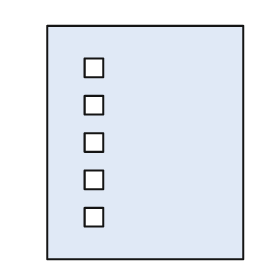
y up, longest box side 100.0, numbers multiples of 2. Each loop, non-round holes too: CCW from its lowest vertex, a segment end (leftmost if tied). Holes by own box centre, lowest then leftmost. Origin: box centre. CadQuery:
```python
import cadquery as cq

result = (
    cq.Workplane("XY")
    .moveTo(-42.0, -50.0)
    .lineTo(42.0, -50.0)
    .lineTo(42.0, 50.0)
    .lineTo(-42.0, 50.0)
    .close()
    .moveTo(-26.0, -36.0)
    .lineTo(-18.0, -36.0)
    .lineTo(-18.0, -28.0)
    .lineTo(-26.0, -28.0)
    .close()
    .moveTo(-26.0, -20.0)
    .lineTo(-18.0, -20.0)
    .lineTo(-18.0, -12.0)
    .lineTo(-26.0, -12.0)
    .close()
    .moveTo(-26.0, -4.0)
    .lineTo(-18.0, -4.0)
    .lineTo(-18.0, 4.0)
    .lineTo(-26.0, 4.0)
    .close()
    .moveTo(-26.0, 12.0)
    .lineTo(-18.0, 12.0)
    .lineTo(-18.0, 20.0)
    .lineTo(-26.0, 20.0)
    .close()
    .moveTo(-26.0, 28.0)
    .lineTo(-18.0, 28.0)
    .lineTo(-18.0, 36.0)
    .lineTo(-26.0, 36.0)
    .close()
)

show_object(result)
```